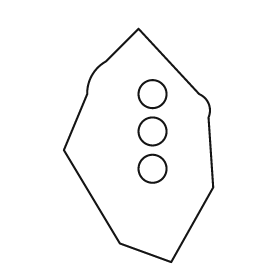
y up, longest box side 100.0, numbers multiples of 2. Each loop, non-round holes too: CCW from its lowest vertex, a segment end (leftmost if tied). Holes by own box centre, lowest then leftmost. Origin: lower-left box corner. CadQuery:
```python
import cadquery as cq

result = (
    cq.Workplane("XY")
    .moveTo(46.0, 0.0)
    .lineTo(64.0, 32.0)
    .lineTo(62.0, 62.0)
    .threePointArc((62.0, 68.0), (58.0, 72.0))
    .lineTo(32.0, 100.0)
    .lineTo(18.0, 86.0)
    .threePointArc((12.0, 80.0), (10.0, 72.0))
    .lineTo(0.0, 48.0)
    .lineTo(24.0, 8.0)
    .close()
    .moveTo(38.0, 40.0)
    .circle(6.0)
    .moveTo(38.0, 56.0)
    .circle(6.0)
    .moveTo(38.0, 72.0)
    .circle(6.0)
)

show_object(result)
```